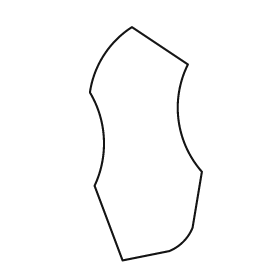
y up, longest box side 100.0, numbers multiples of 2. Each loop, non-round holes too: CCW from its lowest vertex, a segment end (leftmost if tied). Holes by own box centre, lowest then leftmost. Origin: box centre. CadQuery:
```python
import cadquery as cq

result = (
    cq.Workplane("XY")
    .moveTo(-10.0, -50.0)
    .lineTo(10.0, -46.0)
    .threePointArc((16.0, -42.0), (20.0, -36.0))
    .lineTo(24.0, -12.0)
    .threePointArc((14.0, 10.0), (18.0, 34.0))
    .lineTo(-6.0, 50.0)
    .threePointArc((-18.0, 38.0), (-24.0, 22.0))
    .threePointArc((-18.0, 2.0), (-22.0, -18.0))
    .close()
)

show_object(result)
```